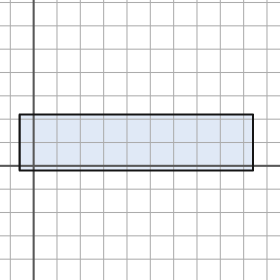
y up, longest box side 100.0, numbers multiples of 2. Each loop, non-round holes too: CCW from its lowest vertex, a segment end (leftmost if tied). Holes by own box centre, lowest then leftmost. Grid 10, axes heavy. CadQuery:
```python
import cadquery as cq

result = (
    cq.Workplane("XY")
    .moveTo(-6.0, -2.0)
    .lineTo(94.0, -2.0)
    .lineTo(94.0, 22.0)
    .lineTo(-6.0, 22.0)
    .close()
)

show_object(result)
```